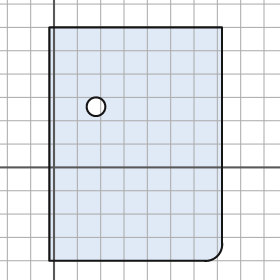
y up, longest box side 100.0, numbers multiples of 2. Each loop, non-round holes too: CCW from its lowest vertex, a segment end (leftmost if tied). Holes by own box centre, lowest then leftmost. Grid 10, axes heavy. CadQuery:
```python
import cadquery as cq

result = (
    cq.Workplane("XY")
    .moveTo(-2.0, -40.0)
    .lineTo(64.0, -40.0)
    .threePointArc((70.0, -38.0), (72.0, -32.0))
    .lineTo(72.0, 60.0)
    .lineTo(-2.0, 60.0)
    .close()
    .moveTo(18.0, 26.0)
    .circle(4.0)
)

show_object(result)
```